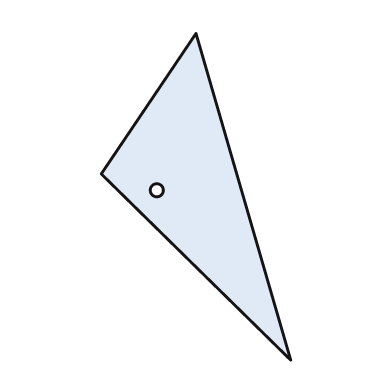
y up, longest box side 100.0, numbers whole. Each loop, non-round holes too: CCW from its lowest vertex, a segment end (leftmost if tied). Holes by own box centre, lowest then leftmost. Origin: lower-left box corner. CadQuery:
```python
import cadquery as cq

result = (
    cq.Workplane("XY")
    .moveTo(58.0, 0.0)
    .lineTo(29.0, 100.0)
    .lineTo(0.0, 57.0)
    .close()
    .moveTo(17.0, 52.0)
    .circle(2.0)
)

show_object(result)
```